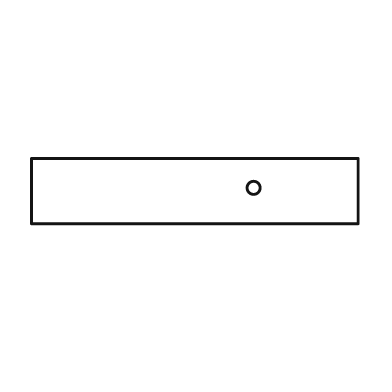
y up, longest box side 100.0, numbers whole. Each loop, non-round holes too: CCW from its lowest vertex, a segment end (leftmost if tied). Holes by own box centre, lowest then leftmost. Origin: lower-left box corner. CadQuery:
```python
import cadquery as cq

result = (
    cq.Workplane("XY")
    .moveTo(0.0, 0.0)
    .lineTo(100.0, 0.0)
    .lineTo(100.0, 20.0)
    .lineTo(0.0, 20.0)
    .close()
    .moveTo(68.0, 11.0)
    .circle(2.0)
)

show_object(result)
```